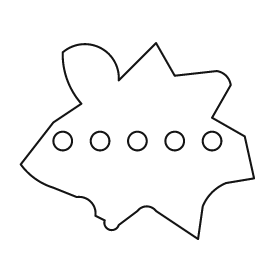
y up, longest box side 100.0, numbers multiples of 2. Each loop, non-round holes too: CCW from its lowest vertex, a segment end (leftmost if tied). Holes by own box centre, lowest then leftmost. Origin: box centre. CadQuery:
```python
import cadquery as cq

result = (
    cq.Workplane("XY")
    .moveTo(26.0, -42.0)
    .lineTo(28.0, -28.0)
    .threePointArc((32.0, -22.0), (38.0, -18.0))
    .lineTo(50.0, -16.0)
    .lineTo(46.0, 2.0)
    .lineTo(32.0, 10.0)
    .lineTo(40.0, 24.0)
    .threePointArc((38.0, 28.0), (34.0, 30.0))
    .lineTo(16.0, 28.0)
    .lineTo(8.0, 42.0)
    .lineTo(-8.0, 26.0)
    .threePointArc((-16.0, 40.0), (-32.0, 38.0))
    .threePointArc((-30.0, 26.0), (-24.0, 16.0))
    .lineTo(-36.0, 8.0)
    .lineTo(-50.0, -10.0)
    .threePointArc((-44.0, -16.0), (-36.0, -20.0))
    .lineTo(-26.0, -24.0)
    .threePointArc((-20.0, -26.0), (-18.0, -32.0))
    .lineTo(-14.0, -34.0)
    .threePointArc((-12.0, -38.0), (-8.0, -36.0))
    .lineTo(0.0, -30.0)
    .threePointArc((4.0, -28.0), (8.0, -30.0))
    .close()
    .moveTo(-32.0, 0.0)
    .circle(4.0)
    .moveTo(-16.0, 0.0)
    .circle(4.0)
    .moveTo(0.0, 0.0)
    .circle(4.0)
    .moveTo(16.0, 0.0)
    .circle(4.0)
    .moveTo(32.0, 0.0)
    .circle(4.0)
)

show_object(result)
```